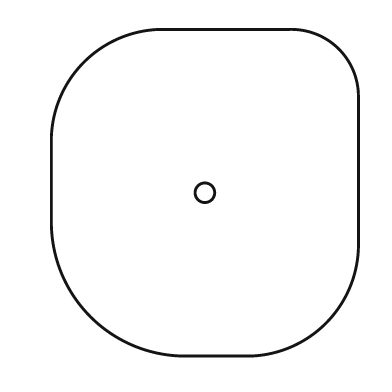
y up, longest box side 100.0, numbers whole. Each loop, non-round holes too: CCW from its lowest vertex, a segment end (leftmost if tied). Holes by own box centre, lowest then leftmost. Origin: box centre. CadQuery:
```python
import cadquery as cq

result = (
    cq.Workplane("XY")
    .moveTo(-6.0, -50.0)
    .lineTo(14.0, -50.0)
    .threePointArc((37.0, -40.0), (47.0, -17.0))
    .lineTo(47.0, 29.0)
    .threePointArc((41.0, 44.0), (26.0, 50.0))
    .lineTo(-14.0, 50.0)
    .threePointArc((-37.0, 40.0), (-47.0, 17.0))
    .lineTo(-47.0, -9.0)
    .threePointArc((-35.0, -38.0), (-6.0, -50.0))
    .close()
    .moveTo(0.0, 0.0)
    .circle(3.0)
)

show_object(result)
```